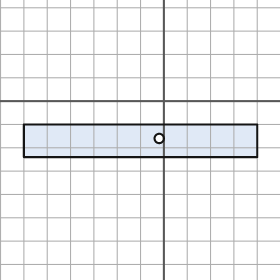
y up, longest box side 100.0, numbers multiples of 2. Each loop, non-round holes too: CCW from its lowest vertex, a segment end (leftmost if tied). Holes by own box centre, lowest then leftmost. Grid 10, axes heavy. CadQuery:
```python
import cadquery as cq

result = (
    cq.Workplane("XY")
    .moveTo(-60.0, -24.0)
    .lineTo(40.0, -24.0)
    .lineTo(40.0, -10.0)
    .lineTo(-60.0, -10.0)
    .close()
    .moveTo(-2.0, -16.0)
    .circle(2.0)
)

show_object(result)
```